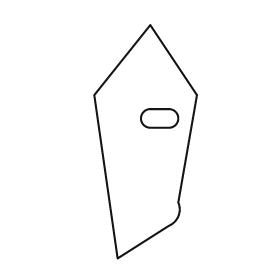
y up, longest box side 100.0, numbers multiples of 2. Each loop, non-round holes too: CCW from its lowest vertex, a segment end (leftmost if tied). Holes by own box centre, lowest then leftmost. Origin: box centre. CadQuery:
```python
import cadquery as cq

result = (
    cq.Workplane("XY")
    .moveTo(-12.0, -50.0)
    .lineTo(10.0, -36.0)
    .threePointArc((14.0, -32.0), (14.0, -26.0))
    .lineTo(22.0, 20.0)
    .lineTo(2.0, 50.0)
    .lineTo(-22.0, 20.0)
    .close()
    .moveTo(2.0, 6.0)
    .lineTo(10.0, 6.0)
    .threePointArc((14.0, 10.0), (10.0, 14.0))
    .lineTo(2.0, 14.0)
    .threePointArc((-2.0, 10.0), (2.0, 6.0))
    .close()
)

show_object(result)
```